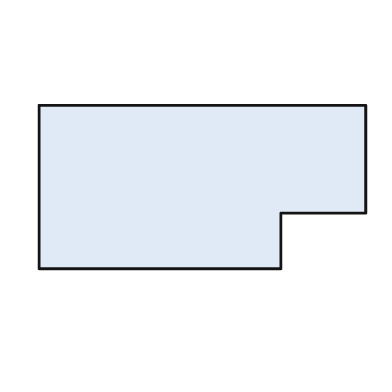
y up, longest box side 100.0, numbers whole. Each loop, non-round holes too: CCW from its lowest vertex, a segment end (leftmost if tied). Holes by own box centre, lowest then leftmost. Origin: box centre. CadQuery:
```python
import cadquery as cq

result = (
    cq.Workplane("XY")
    .moveTo(-50.0, -25.0)
    .lineTo(24.0, -25.0)
    .lineTo(24.0, -8.0)
    .lineTo(50.0, -8.0)
    .lineTo(50.0, 25.0)
    .lineTo(-50.0, 25.0)
    .close()
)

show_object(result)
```